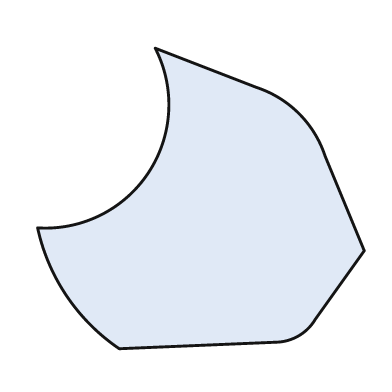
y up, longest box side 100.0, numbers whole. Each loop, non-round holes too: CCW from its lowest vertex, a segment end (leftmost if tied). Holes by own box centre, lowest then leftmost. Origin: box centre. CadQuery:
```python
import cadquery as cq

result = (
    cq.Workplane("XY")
    .moveTo(-25.0, -46.0)
    .lineTo(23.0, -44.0)
    .threePointArc((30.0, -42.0), (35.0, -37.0))
    .lineTo(50.0, -16.0)
    .lineTo(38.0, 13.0)
    .threePointArc((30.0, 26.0), (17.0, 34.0))
    .lineTo(-14.0, 46.0)
    .threePointArc((-16.0, 8.0), (-50.0, -9.0))
    .threePointArc((-41.0, -30.0), (-25.0, -46.0))
    .close()
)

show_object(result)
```